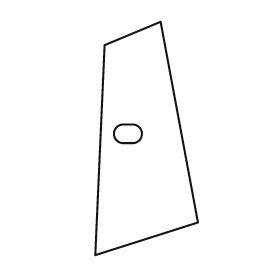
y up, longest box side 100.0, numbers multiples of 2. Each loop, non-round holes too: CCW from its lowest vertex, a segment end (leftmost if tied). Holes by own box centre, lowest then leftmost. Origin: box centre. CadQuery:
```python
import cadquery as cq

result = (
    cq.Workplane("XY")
    .moveTo(-22.0, -50.0)
    .lineTo(22.0, -36.0)
    .lineTo(6.0, 50.0)
    .lineTo(-18.0, 40.0)
    .close()
    .moveTo(-10.0, -2.0)
    .lineTo(-6.0, -2.0)
    .threePointArc((-2.0, 2.0), (-6.0, 6.0))
    .lineTo(-10.0, 6.0)
    .threePointArc((-14.0, 2.0), (-10.0, -2.0))
    .close()
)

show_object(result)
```